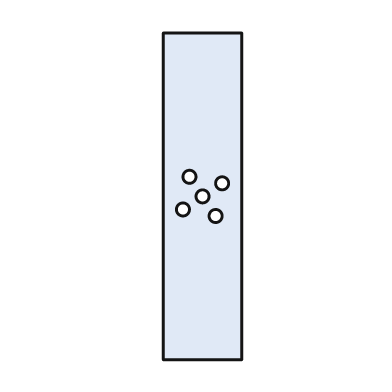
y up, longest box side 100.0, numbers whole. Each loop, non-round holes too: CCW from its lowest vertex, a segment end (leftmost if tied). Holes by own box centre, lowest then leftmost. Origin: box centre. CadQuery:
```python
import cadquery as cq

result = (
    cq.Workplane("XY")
    .moveTo(-12.0, -50.0)
    .lineTo(12.0, -50.0)
    .lineTo(12.0, 50.0)
    .lineTo(-12.0, 50.0)
    .close()
    .moveTo(4.0, -6.0)
    .circle(2.0)
    .moveTo(-6.0, -4.0)
    .circle(2.0)
    .moveTo(0.0, 0.0)
    .circle(2.0)
    .moveTo(6.0, 4.0)
    .circle(2.0)
    .moveTo(-4.0, 6.0)
    .circle(2.0)
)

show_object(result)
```